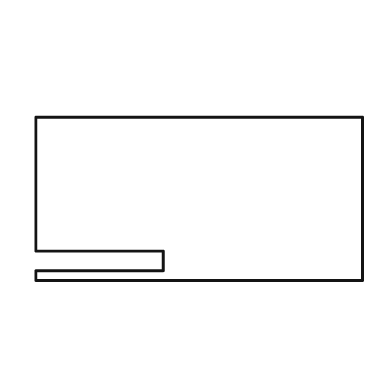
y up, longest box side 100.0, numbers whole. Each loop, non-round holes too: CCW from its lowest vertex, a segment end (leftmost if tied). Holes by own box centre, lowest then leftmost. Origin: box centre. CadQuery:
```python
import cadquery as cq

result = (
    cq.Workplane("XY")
    .moveTo(-50.0, -25.0)
    .lineTo(50.0, -25.0)
    .lineTo(50.0, 25.0)
    .lineTo(-50.0, 25.0)
    .lineTo(-50.0, -16.0)
    .lineTo(-11.0, -16.0)
    .lineTo(-11.0, -22.0)
    .lineTo(-50.0, -22.0)
    .close()
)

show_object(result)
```